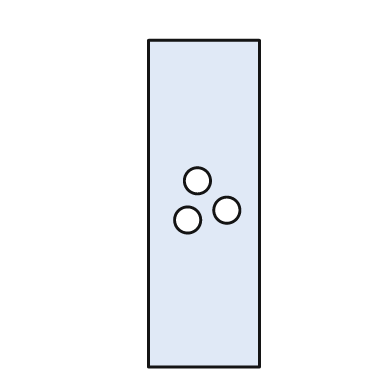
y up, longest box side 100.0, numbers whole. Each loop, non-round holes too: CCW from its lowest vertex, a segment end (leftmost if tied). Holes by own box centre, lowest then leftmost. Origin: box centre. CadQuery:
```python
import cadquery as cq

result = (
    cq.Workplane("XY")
    .moveTo(-17.0, -50.0)
    .lineTo(17.0, -50.0)
    .lineTo(17.0, 50.0)
    .lineTo(-17.0, 50.0)
    .close()
    .moveTo(-5.0, -5.0)
    .circle(4.0)
    .moveTo(7.0, -2.0)
    .circle(4.0)
    .moveTo(-2.0, 7.0)
    .circle(4.0)
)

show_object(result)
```